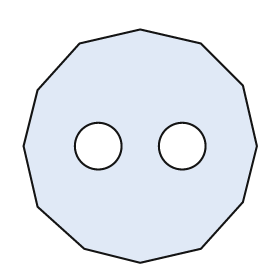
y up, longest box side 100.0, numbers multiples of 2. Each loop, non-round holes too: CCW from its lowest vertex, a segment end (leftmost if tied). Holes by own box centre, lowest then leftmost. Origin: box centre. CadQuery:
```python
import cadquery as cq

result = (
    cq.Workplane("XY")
    .moveTo(0.0, -50.0)
    .lineTo(26.0, -44.0)
    .lineTo(44.0, -24.0)
    .lineTo(50.0, 0.0)
    .lineTo(44.0, 26.0)
    .lineTo(26.0, 44.0)
    .lineTo(0.0, 50.0)
    .lineTo(-26.0, 44.0)
    .lineTo(-44.0, 24.0)
    .lineTo(-50.0, 0.0)
    .lineTo(-44.0, -26.0)
    .lineTo(-24.0, -44.0)
    .close()
    .moveTo(-18.0, 0.0)
    .circle(10.0)
    .moveTo(18.0, 0.0)
    .circle(10.0)
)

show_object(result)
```